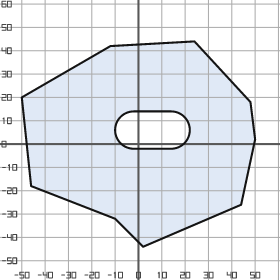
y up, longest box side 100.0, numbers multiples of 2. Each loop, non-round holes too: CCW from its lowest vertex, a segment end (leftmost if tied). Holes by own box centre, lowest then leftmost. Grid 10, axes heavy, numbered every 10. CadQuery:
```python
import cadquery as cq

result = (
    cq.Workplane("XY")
    .moveTo(2.0, -44.0)
    .lineTo(44.0, -26.0)
    .lineTo(50.0, 2.0)
    .lineTo(48.0, 18.0)
    .lineTo(24.0, 44.0)
    .lineTo(-12.0, 42.0)
    .lineTo(-50.0, 20.0)
    .lineTo(-46.0, -18.0)
    .lineTo(-10.0, -32.0)
    .close()
    .moveTo(-2.0, -2.0)
    .lineTo(14.0, -2.0)
    .threePointArc((22.0, 6.0), (14.0, 14.0))
    .lineTo(-2.0, 14.0)
    .threePointArc((-10.0, 6.0), (-2.0, -2.0))
    .close()
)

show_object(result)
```